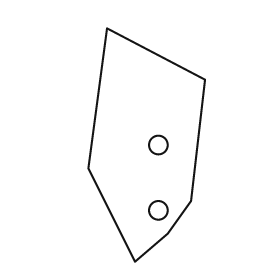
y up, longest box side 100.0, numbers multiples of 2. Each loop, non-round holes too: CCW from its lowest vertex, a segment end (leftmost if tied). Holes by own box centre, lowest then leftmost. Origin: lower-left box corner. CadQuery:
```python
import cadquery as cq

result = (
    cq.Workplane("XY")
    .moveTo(20.0, 0.0)
    .lineTo(34.0, 12.0)
    .lineTo(44.0, 26.0)
    .lineTo(50.0, 78.0)
    .lineTo(8.0, 100.0)
    .lineTo(0.0, 40.0)
    .close()
    .moveTo(30.0, 22.0)
    .circle(4.0)
    .moveTo(30.0, 50.0)
    .circle(4.0)
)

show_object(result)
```